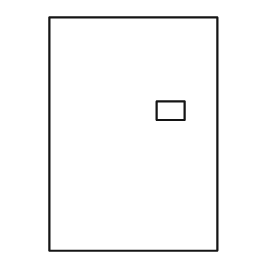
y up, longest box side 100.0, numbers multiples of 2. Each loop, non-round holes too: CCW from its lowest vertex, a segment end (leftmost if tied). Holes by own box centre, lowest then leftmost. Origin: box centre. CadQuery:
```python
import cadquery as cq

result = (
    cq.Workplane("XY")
    .moveTo(-36.0, -50.0)
    .lineTo(36.0, -50.0)
    .lineTo(36.0, 50.0)
    .lineTo(-36.0, 50.0)
    .close()
    .moveTo(10.0, 6.0)
    .lineTo(22.0, 6.0)
    .lineTo(22.0, 14.0)
    .lineTo(10.0, 14.0)
    .close()
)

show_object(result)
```